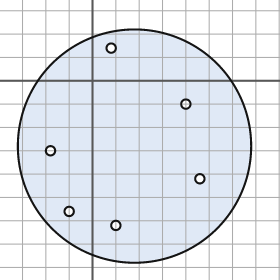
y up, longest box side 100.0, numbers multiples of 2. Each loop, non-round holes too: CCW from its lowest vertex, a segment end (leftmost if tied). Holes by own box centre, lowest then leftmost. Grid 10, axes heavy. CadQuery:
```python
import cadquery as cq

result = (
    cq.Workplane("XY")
    .moveTo(18.0, -28.0)
    .circle(50.0)
    .moveTo(10.0, -62.0)
    .circle(2.0)
    .moveTo(-10.0, -56.0)
    .circle(2.0)
    .moveTo(46.0, -42.0)
    .circle(2.0)
    .moveTo(-18.0, -30.0)
    .circle(2.0)
    .moveTo(40.0, -10.0)
    .circle(2.0)
    .moveTo(8.0, 14.0)
    .circle(2.0)
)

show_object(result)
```